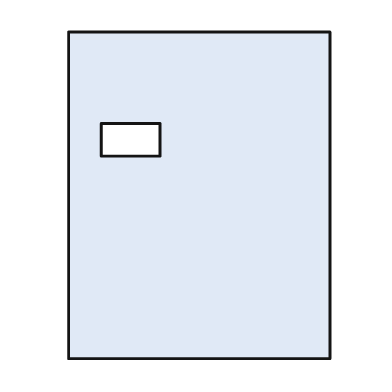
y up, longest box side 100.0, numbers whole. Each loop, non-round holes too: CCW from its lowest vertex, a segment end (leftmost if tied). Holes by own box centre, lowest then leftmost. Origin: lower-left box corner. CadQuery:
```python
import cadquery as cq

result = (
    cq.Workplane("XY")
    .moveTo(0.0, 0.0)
    .lineTo(80.0, 0.0)
    .lineTo(80.0, 100.0)
    .lineTo(0.0, 100.0)
    .close()
    .moveTo(10.0, 62.0)
    .lineTo(28.0, 62.0)
    .lineTo(28.0, 72.0)
    .lineTo(10.0, 72.0)
    .close()
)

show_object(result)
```